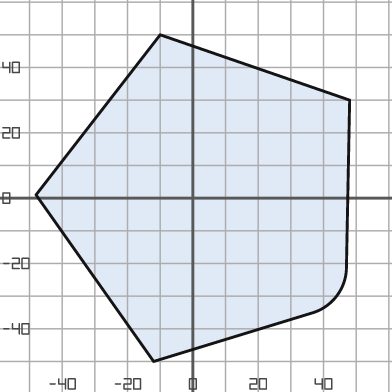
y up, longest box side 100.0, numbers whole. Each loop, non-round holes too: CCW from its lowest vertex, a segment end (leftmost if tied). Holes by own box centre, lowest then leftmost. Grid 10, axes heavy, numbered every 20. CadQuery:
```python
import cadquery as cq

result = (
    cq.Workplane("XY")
    .moveTo(-12.0, -50.0)
    .lineTo(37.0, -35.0)
    .threePointArc((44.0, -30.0), (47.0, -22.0))
    .lineTo(48.0, 30.0)
    .lineTo(-10.0, 50.0)
    .lineTo(-48.0, 1.0)
    .close()
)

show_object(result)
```